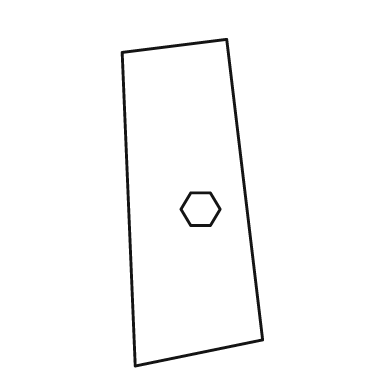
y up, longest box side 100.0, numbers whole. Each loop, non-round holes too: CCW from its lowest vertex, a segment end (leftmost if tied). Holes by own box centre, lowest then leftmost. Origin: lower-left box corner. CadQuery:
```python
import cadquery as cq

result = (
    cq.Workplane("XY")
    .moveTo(4.0, 0.0)
    .lineTo(43.0, 8.0)
    .lineTo(32.0, 100.0)
    .lineTo(0.0, 96.0)
    .close()
    .moveTo(21.0, 43.0)
    .lineTo(27.0, 43.0)
    .lineTo(30.0, 48.0)
    .lineTo(27.0, 53.0)
    .lineTo(21.0, 53.0)
    .lineTo(18.0, 48.0)
    .close()
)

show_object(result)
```